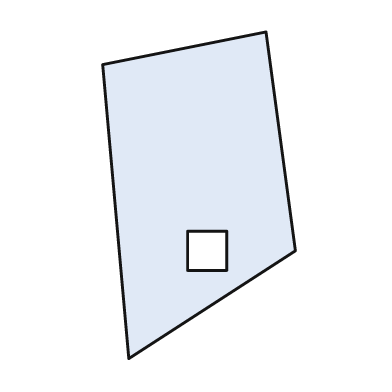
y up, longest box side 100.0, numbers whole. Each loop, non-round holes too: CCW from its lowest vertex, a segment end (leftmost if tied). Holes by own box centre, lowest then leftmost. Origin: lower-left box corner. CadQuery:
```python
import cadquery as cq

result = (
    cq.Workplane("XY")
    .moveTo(8.0, 0.0)
    .lineTo(59.0, 33.0)
    .lineTo(50.0, 100.0)
    .lineTo(0.0, 90.0)
    .close()
    .moveTo(26.0, 27.0)
    .lineTo(38.0, 27.0)
    .lineTo(38.0, 39.0)
    .lineTo(26.0, 39.0)
    .close()
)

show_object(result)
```